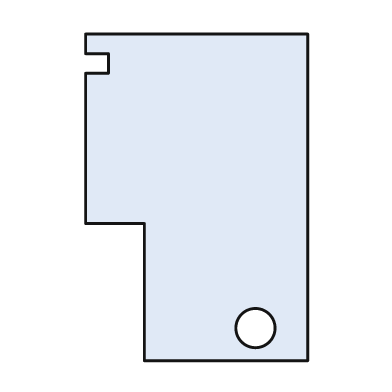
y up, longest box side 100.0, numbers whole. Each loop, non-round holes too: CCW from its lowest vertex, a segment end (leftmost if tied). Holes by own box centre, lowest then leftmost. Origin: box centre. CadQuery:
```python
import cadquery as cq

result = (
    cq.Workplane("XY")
    .moveTo(-16.0, -50.0)
    .lineTo(34.0, -50.0)
    .lineTo(34.0, 50.0)
    .lineTo(-34.0, 50.0)
    .lineTo(-34.0, 44.0)
    .lineTo(-27.0, 44.0)
    .lineTo(-27.0, 38.0)
    .lineTo(-34.0, 38.0)
    .lineTo(-34.0, -8.0)
    .lineTo(-16.0, -8.0)
    .close()
    .moveTo(18.0, -40.0)
    .circle(6.0)
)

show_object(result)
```